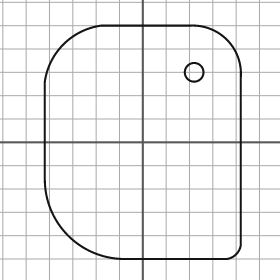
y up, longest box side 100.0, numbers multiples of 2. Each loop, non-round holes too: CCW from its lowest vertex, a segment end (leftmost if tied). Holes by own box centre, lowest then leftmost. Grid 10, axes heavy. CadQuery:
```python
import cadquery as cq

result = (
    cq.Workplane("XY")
    .moveTo(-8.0, -50.0)
    .lineTo(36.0, -50.0)
    .threePointArc((40.0, -48.0), (42.0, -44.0))
    .lineTo(42.0, 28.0)
    .threePointArc((36.0, 44.0), (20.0, 50.0))
    .lineTo(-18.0, 50.0)
    .threePointArc((-34.0, 42.0), (-42.0, 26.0))
    .lineTo(-42.0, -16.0)
    .threePointArc((-32.0, -40.0), (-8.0, -50.0))
    .close()
    .moveTo(22.0, 30.0)
    .circle(4.0)
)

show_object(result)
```